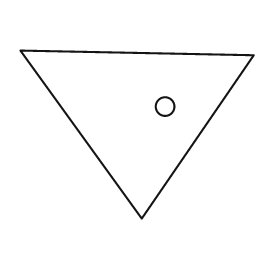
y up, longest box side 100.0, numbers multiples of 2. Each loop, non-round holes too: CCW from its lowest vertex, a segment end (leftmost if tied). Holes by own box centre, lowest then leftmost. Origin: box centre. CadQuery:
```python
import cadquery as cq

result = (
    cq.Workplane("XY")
    .moveTo(2.0, -36.0)
    .lineTo(50.0, 34.0)
    .lineTo(-50.0, 36.0)
    .close()
    .moveTo(12.0, 12.0)
    .circle(4.0)
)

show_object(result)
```